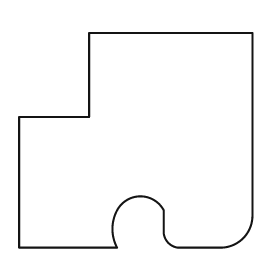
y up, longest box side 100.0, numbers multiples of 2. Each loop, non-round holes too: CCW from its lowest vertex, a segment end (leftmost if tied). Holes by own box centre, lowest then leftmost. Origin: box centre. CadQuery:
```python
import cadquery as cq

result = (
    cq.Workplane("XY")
    .moveTo(-50.0, -46.0)
    .lineTo(-8.0, -46.0)
    .threePointArc((-10.0, -38.0), (-8.0, -30.0))
    .threePointArc((2.0, -24.0), (12.0, -30.0))
    .lineTo(12.0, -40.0)
    .threePointArc((14.0, -44.0), (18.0, -46.0))
    .lineTo(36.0, -46.0)
    .threePointArc((46.0, -42.0), (50.0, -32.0))
    .lineTo(50.0, 46.0)
    .lineTo(-20.0, 46.0)
    .lineTo(-20.0, 10.0)
    .lineTo(-50.0, 10.0)
    .close()
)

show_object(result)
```